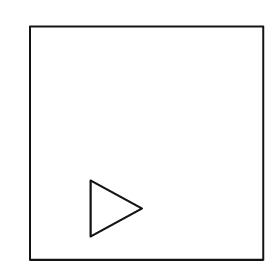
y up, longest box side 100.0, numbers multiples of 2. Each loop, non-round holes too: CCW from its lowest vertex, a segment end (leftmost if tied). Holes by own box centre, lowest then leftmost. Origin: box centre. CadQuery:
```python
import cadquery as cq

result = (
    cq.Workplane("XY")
    .moveTo(-50.0, -50.0)
    .lineTo(50.0, -50.0)
    .lineTo(50.0, 50.0)
    .lineTo(-50.0, 50.0)
    .close()
    .moveTo(-24.0, -40.0)
    .lineTo(-2.0, -28.0)
    .lineTo(-24.0, -16.0)
    .close()
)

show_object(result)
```